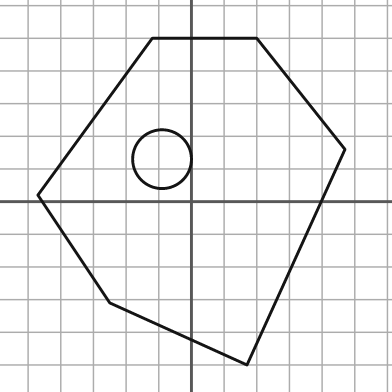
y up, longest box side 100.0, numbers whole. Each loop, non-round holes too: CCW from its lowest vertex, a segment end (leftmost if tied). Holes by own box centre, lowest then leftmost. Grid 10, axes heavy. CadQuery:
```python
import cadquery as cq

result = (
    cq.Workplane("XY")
    .moveTo(17.0, -50.0)
    .lineTo(47.0, 16.0)
    .lineTo(20.0, 50.0)
    .lineTo(-12.0, 50.0)
    .lineTo(-47.0, 2.0)
    .lineTo(-25.0, -31.0)
    .close()
    .moveTo(-9.0, 13.0)
    .circle(9.0)
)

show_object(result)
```